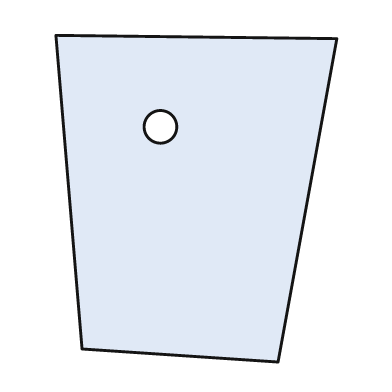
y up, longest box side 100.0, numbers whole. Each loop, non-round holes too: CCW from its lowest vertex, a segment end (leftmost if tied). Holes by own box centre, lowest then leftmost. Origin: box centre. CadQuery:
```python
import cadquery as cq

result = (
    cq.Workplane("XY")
    .moveTo(25.0, -50.0)
    .lineTo(43.0, 49.0)
    .lineTo(-43.0, 50.0)
    .lineTo(-35.0, -46.0)
    .close()
    .moveTo(-11.0, 22.0)
    .circle(5.0)
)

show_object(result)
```